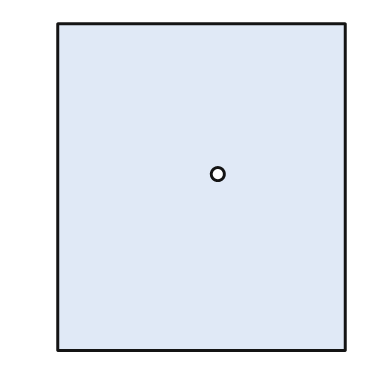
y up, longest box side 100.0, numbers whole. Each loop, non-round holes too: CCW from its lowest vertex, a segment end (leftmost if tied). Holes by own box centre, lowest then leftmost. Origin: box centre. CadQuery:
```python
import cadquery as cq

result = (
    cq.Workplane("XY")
    .moveTo(-44.0, -50.0)
    .lineTo(44.0, -50.0)
    .lineTo(44.0, 50.0)
    .lineTo(-44.0, 50.0)
    .close()
    .moveTo(5.0, 4.0)
    .circle(2.0)
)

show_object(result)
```